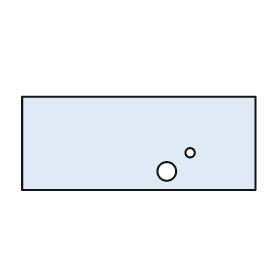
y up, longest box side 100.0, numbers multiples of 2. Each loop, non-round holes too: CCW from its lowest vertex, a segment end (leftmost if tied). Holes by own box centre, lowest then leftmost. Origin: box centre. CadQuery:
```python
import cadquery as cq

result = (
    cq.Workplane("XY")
    .moveTo(-50.0, -20.0)
    .lineTo(50.0, -20.0)
    .lineTo(50.0, 20.0)
    .lineTo(-50.0, 20.0)
    .close()
    .moveTo(12.0, -12.0)
    .circle(4.0)
    .moveTo(22.0, -4.0)
    .circle(2.0)
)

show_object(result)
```